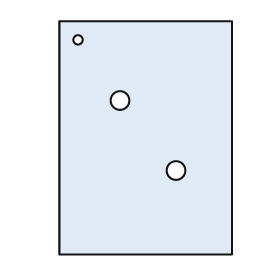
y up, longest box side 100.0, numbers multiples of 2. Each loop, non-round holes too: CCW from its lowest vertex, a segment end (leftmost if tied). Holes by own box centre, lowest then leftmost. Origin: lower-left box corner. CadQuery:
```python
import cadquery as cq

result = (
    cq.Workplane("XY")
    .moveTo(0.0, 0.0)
    .lineTo(74.0, 0.0)
    .lineTo(74.0, 100.0)
    .lineTo(0.0, 100.0)
    .close()
    .moveTo(50.0, 36.0)
    .circle(4.0)
    .moveTo(26.0, 66.0)
    .circle(4.0)
    .moveTo(8.0, 92.0)
    .circle(2.0)
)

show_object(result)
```